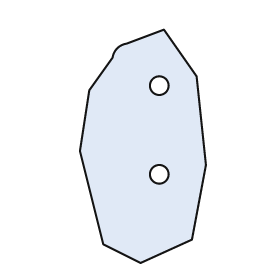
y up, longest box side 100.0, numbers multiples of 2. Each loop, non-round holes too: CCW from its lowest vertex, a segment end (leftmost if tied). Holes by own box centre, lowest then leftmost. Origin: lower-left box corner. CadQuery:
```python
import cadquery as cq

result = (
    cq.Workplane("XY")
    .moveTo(26.0, 0.0)
    .lineTo(48.0, 10.0)
    .lineTo(54.0, 42.0)
    .lineTo(50.0, 80.0)
    .lineTo(36.0, 100.0)
    .lineTo(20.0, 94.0)
    .threePointArc((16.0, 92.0), (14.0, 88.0))
    .lineTo(4.0, 74.0)
    .lineTo(0.0, 48.0)
    .lineTo(10.0, 8.0)
    .close()
    .moveTo(34.0, 38.0)
    .circle(4.0)
    .moveTo(34.0, 76.0)
    .circle(4.0)
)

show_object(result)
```